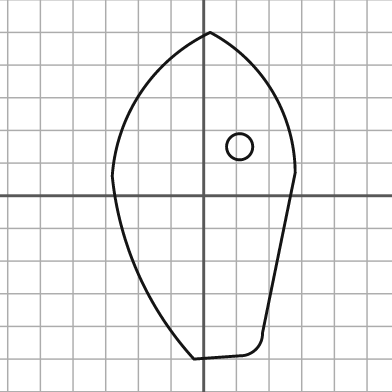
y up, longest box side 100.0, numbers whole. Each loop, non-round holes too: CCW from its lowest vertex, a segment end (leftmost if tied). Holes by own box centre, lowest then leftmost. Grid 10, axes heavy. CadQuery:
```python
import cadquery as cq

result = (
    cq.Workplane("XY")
    .moveTo(-3.0, -50.0)
    .lineTo(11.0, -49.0)
    .threePointArc((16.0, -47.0), (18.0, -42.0))
    .lineTo(28.0, 7.0)
    .threePointArc((21.0, 32.0), (2.0, 50.0))
    .threePointArc((-19.0, 32.0), (-28.0, 6.0))
    .threePointArc((-20.0, -24.0), (-3.0, -50.0))
    .close()
    .moveTo(11.0, 15.0)
    .circle(4.0)
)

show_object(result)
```